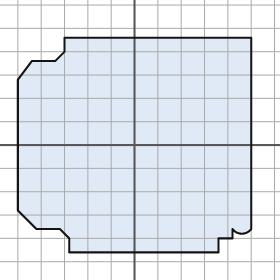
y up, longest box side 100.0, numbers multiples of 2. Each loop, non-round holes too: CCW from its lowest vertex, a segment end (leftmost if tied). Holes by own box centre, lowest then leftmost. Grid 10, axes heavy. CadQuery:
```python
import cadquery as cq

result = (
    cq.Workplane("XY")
    .moveTo(-28.0, -46.0)
    .lineTo(36.0, -46.0)
    .lineTo(36.0, -40.0)
    .lineTo(42.0, -40.0)
    .lineTo(42.0, -36.0)
    .threePointArc((46.0, -38.0), (50.0, -36.0))
    .lineTo(50.0, 46.0)
    .lineTo(-30.0, 46.0)
    .lineTo(-30.0, 40.0)
    .lineTo(-34.0, 36.0)
    .lineTo(-44.0, 36.0)
    .lineTo(-50.0, 28.0)
    .lineTo(-50.0, -28.0)
    .lineTo(-42.0, -36.0)
    .lineTo(-32.0, -36.0)
    .lineTo(-28.0, -40.0)
    .close()
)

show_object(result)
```